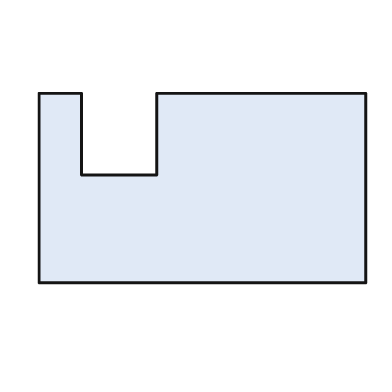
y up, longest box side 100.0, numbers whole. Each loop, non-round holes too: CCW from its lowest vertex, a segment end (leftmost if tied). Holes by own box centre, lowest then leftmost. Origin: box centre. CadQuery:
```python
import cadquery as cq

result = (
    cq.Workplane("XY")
    .moveTo(-50.0, -29.0)
    .lineTo(50.0, -29.0)
    .lineTo(50.0, 29.0)
    .lineTo(-14.0, 29.0)
    .lineTo(-14.0, 4.0)
    .lineTo(-37.0, 4.0)
    .lineTo(-37.0, 29.0)
    .lineTo(-50.0, 29.0)
    .close()
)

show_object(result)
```